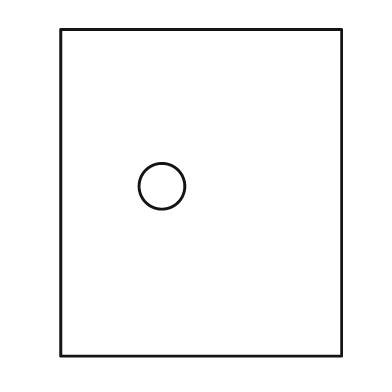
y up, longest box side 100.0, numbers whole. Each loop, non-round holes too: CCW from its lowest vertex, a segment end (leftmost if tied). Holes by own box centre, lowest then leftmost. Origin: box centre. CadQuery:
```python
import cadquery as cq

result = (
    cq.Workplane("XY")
    .moveTo(-43.0, -50.0)
    .lineTo(43.0, -50.0)
    .lineTo(43.0, 50.0)
    .lineTo(-43.0, 50.0)
    .close()
    .moveTo(-12.0, 2.0)
    .circle(7.0)
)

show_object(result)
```